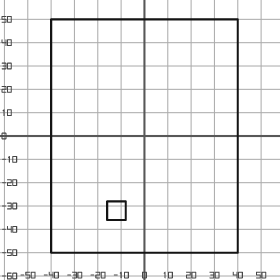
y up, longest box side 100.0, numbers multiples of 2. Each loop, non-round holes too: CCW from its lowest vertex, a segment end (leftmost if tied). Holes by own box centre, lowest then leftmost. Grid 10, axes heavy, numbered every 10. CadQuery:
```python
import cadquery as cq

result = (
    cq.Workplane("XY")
    .moveTo(-40.0, -50.0)
    .lineTo(40.0, -50.0)
    .lineTo(40.0, 50.0)
    .lineTo(-40.0, 50.0)
    .close()
    .moveTo(-16.0, -36.0)
    .lineTo(-8.0, -36.0)
    .lineTo(-8.0, -28.0)
    .lineTo(-16.0, -28.0)
    .close()
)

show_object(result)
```